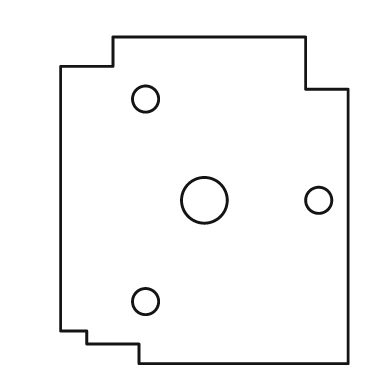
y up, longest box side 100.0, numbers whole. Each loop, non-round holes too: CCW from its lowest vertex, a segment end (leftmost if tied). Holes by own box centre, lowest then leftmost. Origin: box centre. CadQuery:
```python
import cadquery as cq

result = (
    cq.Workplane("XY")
    .moveTo(-20.0, -50.0)
    .lineTo(44.0, -50.0)
    .lineTo(44.0, 34.0)
    .lineTo(31.0, 34.0)
    .lineTo(31.0, 50.0)
    .lineTo(-28.0, 50.0)
    .lineTo(-28.0, 41.0)
    .lineTo(-44.0, 41.0)
    .lineTo(-44.0, -40.0)
    .lineTo(-36.0, -40.0)
    .lineTo(-36.0, -44.0)
    .lineTo(-20.0, -44.0)
    .close()
    .moveTo(-18.0, -31.0)
    .circle(4.0)
    .moveTo(0.0, 0.0)
    .circle(7.0)
    .moveTo(35.0, 0.0)
    .circle(4.0)
    .moveTo(-18.0, 31.0)
    .circle(4.0)
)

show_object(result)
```